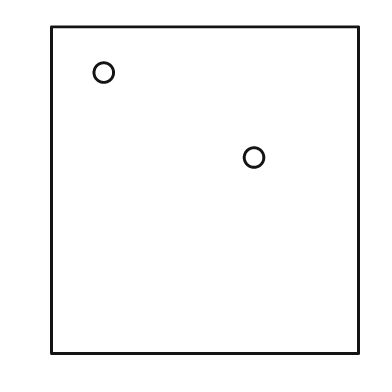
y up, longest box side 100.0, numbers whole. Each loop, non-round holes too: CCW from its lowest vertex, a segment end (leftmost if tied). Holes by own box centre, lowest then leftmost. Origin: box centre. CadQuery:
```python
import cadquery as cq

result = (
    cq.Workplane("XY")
    .moveTo(-47.0, -50.0)
    .lineTo(47.0, -50.0)
    .lineTo(47.0, 50.0)
    .lineTo(-47.0, 50.0)
    .close()
    .moveTo(15.0, 10.0)
    .circle(3.0)
    .moveTo(-31.0, 36.0)
    .circle(3.0)
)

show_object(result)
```